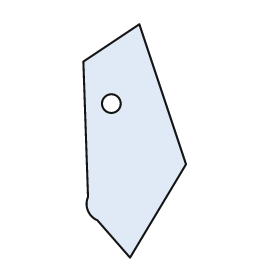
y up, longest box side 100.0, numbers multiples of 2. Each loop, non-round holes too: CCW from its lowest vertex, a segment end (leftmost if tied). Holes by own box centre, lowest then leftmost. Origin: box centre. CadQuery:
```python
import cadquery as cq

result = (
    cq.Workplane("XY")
    .moveTo(-2.0, -50.0)
    .lineTo(22.0, -10.0)
    .lineTo(2.0, 50.0)
    .lineTo(-22.0, 34.0)
    .lineTo(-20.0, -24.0)
    .threePointArc((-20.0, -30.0), (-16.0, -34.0))
    .close()
    .moveTo(-10.0, 16.0)
    .circle(4.0)
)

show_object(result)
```